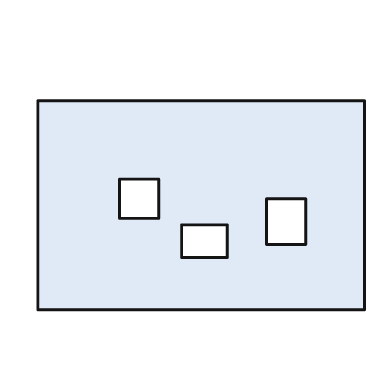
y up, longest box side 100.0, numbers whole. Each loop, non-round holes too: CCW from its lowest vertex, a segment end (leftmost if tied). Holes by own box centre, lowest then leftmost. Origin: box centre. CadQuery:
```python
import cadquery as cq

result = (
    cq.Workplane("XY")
    .moveTo(-50.0, -32.0)
    .lineTo(50.0, -32.0)
    .lineTo(50.0, 32.0)
    .lineTo(-50.0, 32.0)
    .close()
    .moveTo(-6.0, -16.0)
    .lineTo(8.0, -16.0)
    .lineTo(8.0, -6.0)
    .lineTo(-6.0, -6.0)
    .close()
    .moveTo(20.0, -12.0)
    .lineTo(32.0, -12.0)
    .lineTo(32.0, 2.0)
    .lineTo(20.0, 2.0)
    .close()
    .moveTo(-25.0, -4.0)
    .lineTo(-13.0, -4.0)
    .lineTo(-13.0, 8.0)
    .lineTo(-25.0, 8.0)
    .close()
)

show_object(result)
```